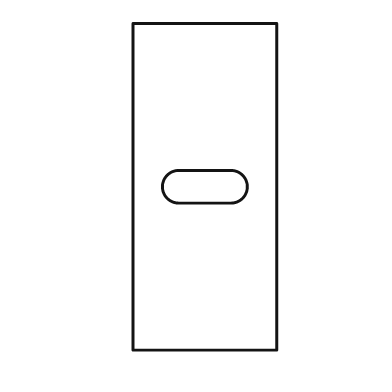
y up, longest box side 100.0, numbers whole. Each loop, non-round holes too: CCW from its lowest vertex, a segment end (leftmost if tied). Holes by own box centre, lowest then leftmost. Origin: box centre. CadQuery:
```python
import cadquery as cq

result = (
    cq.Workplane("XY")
    .moveTo(-22.0, -50.0)
    .lineTo(22.0, -50.0)
    .lineTo(22.0, 50.0)
    .lineTo(-22.0, 50.0)
    .close()
    .moveTo(-8.0, -5.0)
    .lineTo(8.0, -5.0)
    .threePointArc((13.0, 0.0), (8.0, 5.0))
    .lineTo(-8.0, 5.0)
    .threePointArc((-13.0, 0.0), (-8.0, -5.0))
    .close()
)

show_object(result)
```